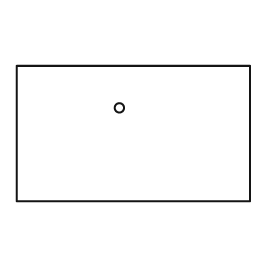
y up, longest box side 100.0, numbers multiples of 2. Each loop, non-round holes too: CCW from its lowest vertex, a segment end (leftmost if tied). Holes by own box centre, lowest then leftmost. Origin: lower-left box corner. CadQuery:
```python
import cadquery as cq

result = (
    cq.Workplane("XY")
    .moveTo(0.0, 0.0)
    .lineTo(100.0, 0.0)
    .lineTo(100.0, 58.0)
    .lineTo(0.0, 58.0)
    .close()
    .moveTo(44.0, 40.0)
    .circle(2.0)
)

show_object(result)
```